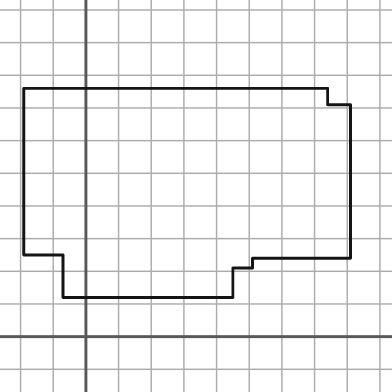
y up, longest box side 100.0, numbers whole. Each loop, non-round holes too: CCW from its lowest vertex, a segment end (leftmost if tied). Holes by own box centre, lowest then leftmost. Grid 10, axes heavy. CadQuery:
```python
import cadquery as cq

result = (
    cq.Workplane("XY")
    .moveTo(-7.0, 12.0)
    .lineTo(45.0, 12.0)
    .lineTo(45.0, 21.0)
    .lineTo(51.0, 21.0)
    .lineTo(51.0, 24.0)
    .lineTo(81.0, 24.0)
    .lineTo(81.0, 71.0)
    .lineTo(74.0, 71.0)
    .lineTo(74.0, 76.0)
    .lineTo(-19.0, 76.0)
    .lineTo(-19.0, 25.0)
    .lineTo(-7.0, 25.0)
    .close()
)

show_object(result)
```